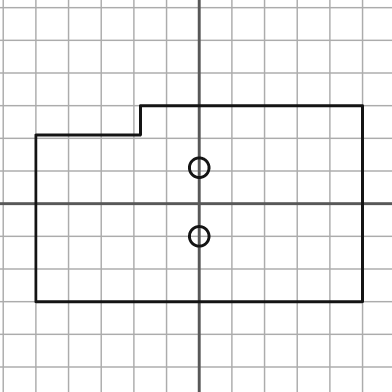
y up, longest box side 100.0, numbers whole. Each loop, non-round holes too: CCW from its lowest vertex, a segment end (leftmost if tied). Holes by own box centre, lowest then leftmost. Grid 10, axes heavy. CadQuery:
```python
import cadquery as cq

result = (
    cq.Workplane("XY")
    .moveTo(-50.0, -30.0)
    .lineTo(50.0, -30.0)
    .lineTo(50.0, 30.0)
    .lineTo(-18.0, 30.0)
    .lineTo(-18.0, 21.0)
    .lineTo(-50.0, 21.0)
    .close()
    .moveTo(0.0, -10.0)
    .circle(3.0)
    .moveTo(0.0, 11.0)
    .circle(3.0)
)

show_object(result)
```